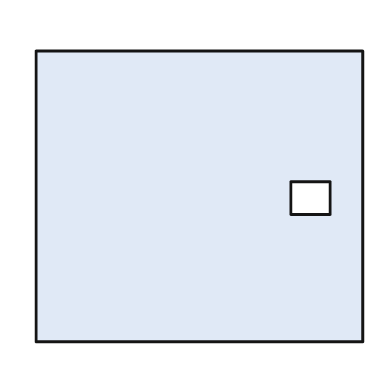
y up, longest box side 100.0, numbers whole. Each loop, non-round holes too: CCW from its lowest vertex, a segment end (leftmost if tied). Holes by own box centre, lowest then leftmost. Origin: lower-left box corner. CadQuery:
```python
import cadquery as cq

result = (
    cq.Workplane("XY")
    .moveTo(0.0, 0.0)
    .lineTo(100.0, 0.0)
    .lineTo(100.0, 89.0)
    .lineTo(0.0, 89.0)
    .close()
    .moveTo(78.0, 39.0)
    .lineTo(90.0, 39.0)
    .lineTo(90.0, 49.0)
    .lineTo(78.0, 49.0)
    .close()
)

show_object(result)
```